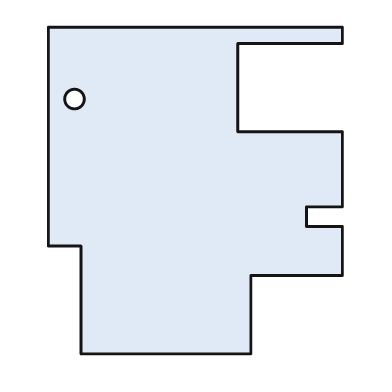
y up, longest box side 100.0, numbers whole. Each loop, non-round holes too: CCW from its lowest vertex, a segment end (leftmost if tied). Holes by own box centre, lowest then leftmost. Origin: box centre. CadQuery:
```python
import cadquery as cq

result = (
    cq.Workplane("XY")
    .moveTo(-35.0, -50.0)
    .lineTo(17.0, -50.0)
    .lineTo(17.0, -26.0)
    .lineTo(45.0, -26.0)
    .lineTo(45.0, -11.0)
    .lineTo(34.0, -11.0)
    .lineTo(34.0, -5.0)
    .lineTo(45.0, -5.0)
    .lineTo(45.0, 18.0)
    .lineTo(13.0, 18.0)
    .lineTo(13.0, 45.0)
    .lineTo(45.0, 45.0)
    .lineTo(45.0, 50.0)
    .lineTo(-45.0, 50.0)
    .lineTo(-45.0, -17.0)
    .lineTo(-35.0, -17.0)
    .close()
    .moveTo(-37.0, 28.0)
    .circle(3.0)
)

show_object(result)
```